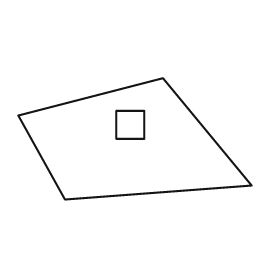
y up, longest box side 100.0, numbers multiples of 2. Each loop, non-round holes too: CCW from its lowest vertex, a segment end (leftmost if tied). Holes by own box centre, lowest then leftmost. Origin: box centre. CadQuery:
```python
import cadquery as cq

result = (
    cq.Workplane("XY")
    .moveTo(-30.0, -26.0)
    .lineTo(50.0, -20.0)
    .lineTo(12.0, 26.0)
    .lineTo(-50.0, 10.0)
    .close()
    .moveTo(-8.0, 0.0)
    .lineTo(4.0, 0.0)
    .lineTo(4.0, 12.0)
    .lineTo(-8.0, 12.0)
    .close()
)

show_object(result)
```